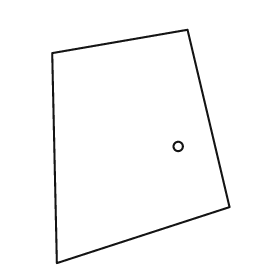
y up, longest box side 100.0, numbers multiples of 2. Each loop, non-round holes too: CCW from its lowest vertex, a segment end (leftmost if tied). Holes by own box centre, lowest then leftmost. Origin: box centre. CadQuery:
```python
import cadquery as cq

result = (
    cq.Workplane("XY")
    .moveTo(-36.0, -50.0)
    .lineTo(38.0, -26.0)
    .lineTo(20.0, 50.0)
    .lineTo(-38.0, 40.0)
    .close()
    .moveTo(16.0, 0.0)
    .circle(2.0)
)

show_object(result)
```